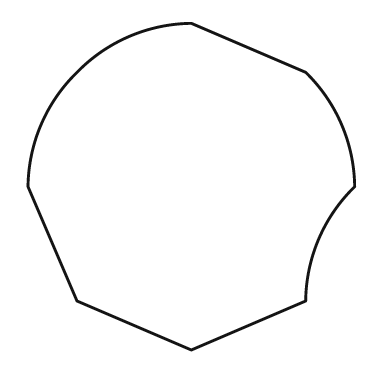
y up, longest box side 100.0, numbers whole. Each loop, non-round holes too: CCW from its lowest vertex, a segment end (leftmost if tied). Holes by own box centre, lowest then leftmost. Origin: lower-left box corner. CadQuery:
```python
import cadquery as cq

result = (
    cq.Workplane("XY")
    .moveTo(50.0, 0.0)
    .lineTo(85.0, 15.0)
    .threePointArc((89.0, 34.0), (100.0, 50.0))
    .threePointArc((96.0, 69.0), (85.0, 85.0))
    .lineTo(50.0, 100.0)
    .threePointArc((31.0, 96.0), (15.0, 85.0))
    .threePointArc((4.0, 69.0), (0.0, 50.0))
    .lineTo(15.0, 15.0)
    .close()
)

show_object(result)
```